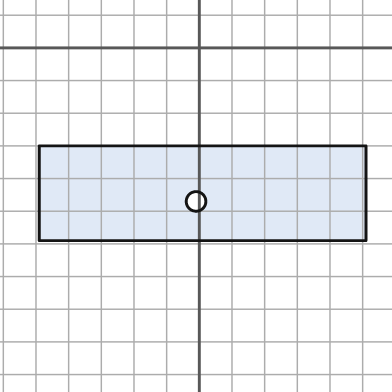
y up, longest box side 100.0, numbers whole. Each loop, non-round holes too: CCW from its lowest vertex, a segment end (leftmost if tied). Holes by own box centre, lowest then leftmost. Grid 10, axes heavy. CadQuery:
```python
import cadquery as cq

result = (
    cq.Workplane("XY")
    .moveTo(-49.0, -59.0)
    .lineTo(51.0, -59.0)
    .lineTo(51.0, -30.0)
    .lineTo(-49.0, -30.0)
    .close()
    .moveTo(-1.0, -47.0)
    .circle(3.0)
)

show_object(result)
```